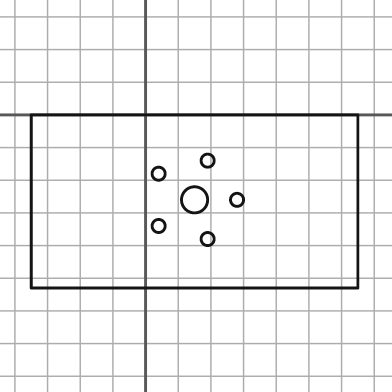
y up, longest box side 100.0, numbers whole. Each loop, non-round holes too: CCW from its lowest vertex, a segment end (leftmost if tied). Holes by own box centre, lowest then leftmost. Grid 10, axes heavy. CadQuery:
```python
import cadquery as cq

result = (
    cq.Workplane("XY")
    .moveTo(-35.0, -53.0)
    .lineTo(65.0, -53.0)
    .lineTo(65.0, 0.0)
    .lineTo(-35.0, 0.0)
    .close()
    .moveTo(19.0, -38.0)
    .circle(2.0)
    .moveTo(4.0, -34.0)
    .circle(2.0)
    .moveTo(15.0, -26.0)
    .circle(4.0)
    .moveTo(28.0, -26.0)
    .circle(2.0)
    .moveTo(4.0, -18.0)
    .circle(2.0)
    .moveTo(19.0, -14.0)
    .circle(2.0)
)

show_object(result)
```